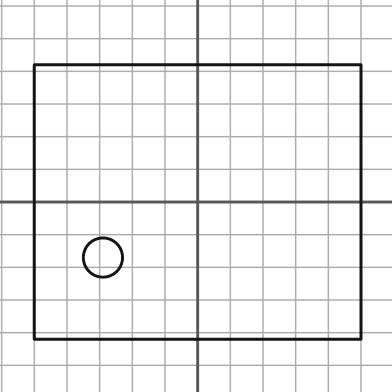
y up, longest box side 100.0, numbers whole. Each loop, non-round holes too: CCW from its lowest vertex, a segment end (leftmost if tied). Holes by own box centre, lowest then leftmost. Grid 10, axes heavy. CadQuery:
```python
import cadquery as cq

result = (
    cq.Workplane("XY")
    .moveTo(-50.0, -42.0)
    .lineTo(50.0, -42.0)
    .lineTo(50.0, 42.0)
    .lineTo(-50.0, 42.0)
    .close()
    .moveTo(-29.0, -17.0)
    .circle(6.0)
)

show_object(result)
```